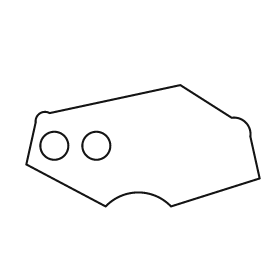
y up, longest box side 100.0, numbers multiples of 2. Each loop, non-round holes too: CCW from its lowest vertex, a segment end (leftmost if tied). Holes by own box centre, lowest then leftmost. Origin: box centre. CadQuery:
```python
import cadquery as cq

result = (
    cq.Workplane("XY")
    .moveTo(-16.0, -26.0)
    .threePointArc((-2.0, -20.0), (12.0, -26.0))
    .lineTo(50.0, -14.0)
    .lineTo(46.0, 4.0)
    .threePointArc((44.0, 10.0), (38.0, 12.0))
    .lineTo(16.0, 26.0)
    .lineTo(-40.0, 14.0)
    .threePointArc((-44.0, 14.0), (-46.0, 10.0))
    .lineTo(-50.0, -8.0)
    .close()
    .moveTo(-38.0, 0.0)
    .circle(6.0)
    .moveTo(-20.0, 0.0)
    .circle(6.0)
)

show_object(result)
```